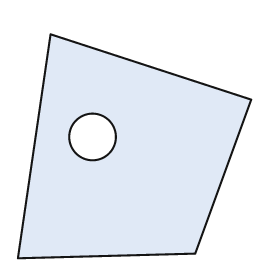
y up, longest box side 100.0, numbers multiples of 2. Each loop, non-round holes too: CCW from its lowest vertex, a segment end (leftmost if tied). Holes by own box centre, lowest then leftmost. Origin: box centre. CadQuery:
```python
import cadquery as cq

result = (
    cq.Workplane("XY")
    .moveTo(-50.0, -48.0)
    .lineTo(26.0, -46.0)
    .lineTo(50.0, 20.0)
    .lineTo(-36.0, 48.0)
    .close()
    .moveTo(-18.0, 4.0)
    .circle(10.0)
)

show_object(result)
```